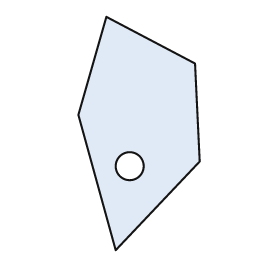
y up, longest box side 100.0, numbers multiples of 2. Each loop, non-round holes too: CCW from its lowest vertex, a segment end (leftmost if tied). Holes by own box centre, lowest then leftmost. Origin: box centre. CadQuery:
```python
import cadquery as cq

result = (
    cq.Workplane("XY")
    .moveTo(-10.0, -50.0)
    .lineTo(26.0, -12.0)
    .lineTo(24.0, 30.0)
    .lineTo(-14.0, 50.0)
    .lineTo(-26.0, 8.0)
    .close()
    .moveTo(-4.0, -14.0)
    .circle(6.0)
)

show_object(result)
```